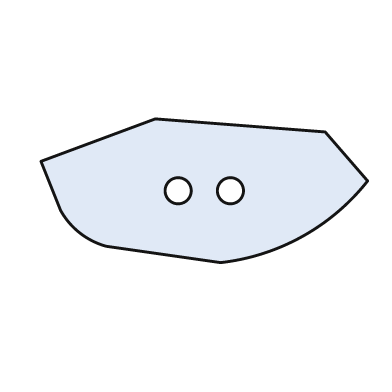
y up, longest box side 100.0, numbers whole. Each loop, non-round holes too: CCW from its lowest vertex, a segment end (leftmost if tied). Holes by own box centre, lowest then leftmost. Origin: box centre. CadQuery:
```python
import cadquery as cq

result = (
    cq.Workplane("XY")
    .moveTo(5.0, -22.0)
    .threePointArc((30.0, -14.0), (50.0, 3.0))
    .lineTo(37.0, 18.0)
    .lineTo(-15.0, 22.0)
    .lineTo(-50.0, 9.0)
    .lineTo(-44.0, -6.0)
    .threePointArc((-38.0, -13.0), (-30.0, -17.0))
    .close()
    .moveTo(-8.0, 0.0)
    .circle(4.0)
    .moveTo(8.0, 0.0)
    .circle(4.0)
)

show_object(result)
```